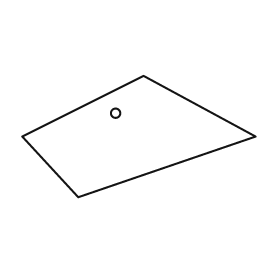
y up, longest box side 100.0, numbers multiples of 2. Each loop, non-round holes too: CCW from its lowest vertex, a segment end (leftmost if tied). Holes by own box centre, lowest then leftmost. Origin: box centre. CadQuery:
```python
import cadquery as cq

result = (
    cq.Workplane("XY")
    .moveTo(-26.0, -26.0)
    .lineTo(50.0, 0.0)
    .lineTo(2.0, 26.0)
    .lineTo(-50.0, 0.0)
    .close()
    .moveTo(-10.0, 10.0)
    .circle(2.0)
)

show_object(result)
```